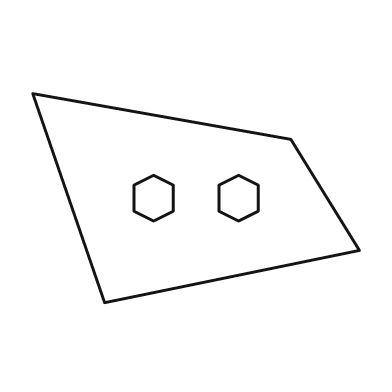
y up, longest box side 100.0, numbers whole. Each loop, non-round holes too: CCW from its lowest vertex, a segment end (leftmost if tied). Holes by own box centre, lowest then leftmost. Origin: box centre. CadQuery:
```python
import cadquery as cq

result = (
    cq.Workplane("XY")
    .moveTo(-28.0, -32.0)
    .lineTo(50.0, -16.0)
    .lineTo(29.0, 18.0)
    .lineTo(-50.0, 32.0)
    .close()
    .moveTo(-13.0, -7.0)
    .lineTo(-7.0, -4.0)
    .lineTo(-7.0, 4.0)
    .lineTo(-13.0, 7.0)
    .lineTo(-19.0, 4.0)
    .lineTo(-19.0, -4.0)
    .close()
    .moveTo(13.0, -7.0)
    .lineTo(19.0, -4.0)
    .lineTo(19.0, 4.0)
    .lineTo(13.0, 7.0)
    .lineTo(7.0, 4.0)
    .lineTo(7.0, -4.0)
    .close()
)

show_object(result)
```